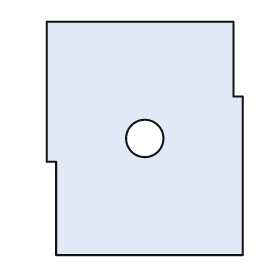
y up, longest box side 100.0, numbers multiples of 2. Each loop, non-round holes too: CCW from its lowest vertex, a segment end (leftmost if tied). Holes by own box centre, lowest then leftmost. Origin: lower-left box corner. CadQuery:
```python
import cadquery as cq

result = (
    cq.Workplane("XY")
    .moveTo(4.0, 0.0)
    .lineTo(84.0, 0.0)
    .lineTo(84.0, 68.0)
    .lineTo(80.0, 68.0)
    .lineTo(80.0, 100.0)
    .lineTo(0.0, 100.0)
    .lineTo(0.0, 40.0)
    .lineTo(4.0, 40.0)
    .close()
    .moveTo(42.0, 50.0)
    .circle(8.0)
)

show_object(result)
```